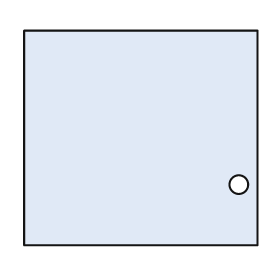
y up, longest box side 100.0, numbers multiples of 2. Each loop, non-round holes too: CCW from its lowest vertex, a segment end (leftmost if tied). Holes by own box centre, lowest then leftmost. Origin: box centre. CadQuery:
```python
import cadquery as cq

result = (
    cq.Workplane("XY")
    .moveTo(-50.0, -46.0)
    .lineTo(50.0, -46.0)
    .lineTo(50.0, 46.0)
    .lineTo(-50.0, 46.0)
    .close()
    .moveTo(42.0, -20.0)
    .circle(4.0)
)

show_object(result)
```